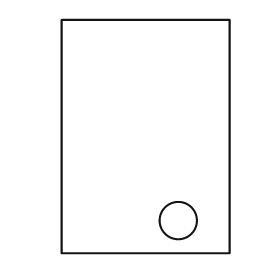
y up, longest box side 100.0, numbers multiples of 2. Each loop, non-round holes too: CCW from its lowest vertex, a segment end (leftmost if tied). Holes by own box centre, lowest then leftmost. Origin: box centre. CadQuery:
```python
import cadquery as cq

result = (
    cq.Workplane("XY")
    .moveTo(-36.0, -50.0)
    .lineTo(36.0, -50.0)
    .lineTo(36.0, 50.0)
    .lineTo(-36.0, 50.0)
    .close()
    .moveTo(14.0, -36.0)
    .circle(8.0)
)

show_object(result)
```